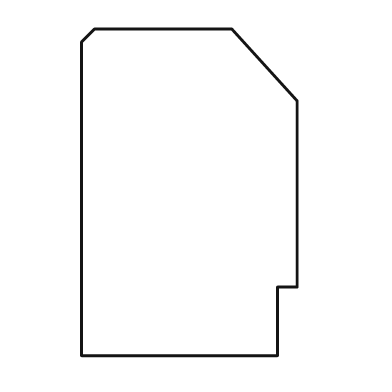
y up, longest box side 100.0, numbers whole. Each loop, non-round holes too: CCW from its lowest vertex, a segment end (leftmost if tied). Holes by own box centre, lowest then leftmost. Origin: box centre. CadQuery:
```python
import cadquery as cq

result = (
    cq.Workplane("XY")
    .moveTo(-33.0, -50.0)
    .lineTo(27.0, -50.0)
    .lineTo(27.0, -29.0)
    .lineTo(33.0, -29.0)
    .lineTo(33.0, 28.0)
    .lineTo(13.0, 50.0)
    .lineTo(-29.0, 50.0)
    .lineTo(-33.0, 46.0)
    .close()
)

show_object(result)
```